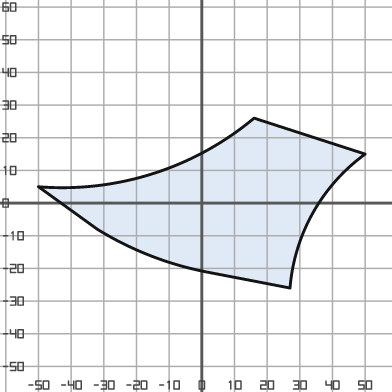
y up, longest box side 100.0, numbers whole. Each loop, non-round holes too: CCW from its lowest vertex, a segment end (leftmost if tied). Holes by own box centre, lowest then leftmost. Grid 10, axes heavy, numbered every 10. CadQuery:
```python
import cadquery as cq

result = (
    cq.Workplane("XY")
    .moveTo(27.0, -26.0)
    .threePointArc((34.0, -3.0), (50.0, 15.0))
    .lineTo(16.0, 26.0)
    .threePointArc((-15.0, 9.0), (-50.0, 5.0))
    .lineTo(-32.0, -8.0)
    .threePointArc((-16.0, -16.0), (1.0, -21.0))
    .close()
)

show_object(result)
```